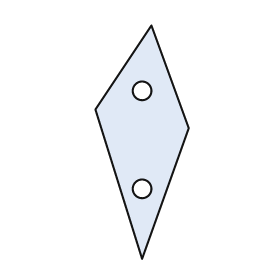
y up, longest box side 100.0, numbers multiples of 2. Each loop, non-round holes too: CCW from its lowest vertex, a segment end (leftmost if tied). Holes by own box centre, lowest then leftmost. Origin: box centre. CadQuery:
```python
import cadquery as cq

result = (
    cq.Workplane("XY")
    .moveTo(0.0, -50.0)
    .lineTo(20.0, 6.0)
    .lineTo(4.0, 50.0)
    .lineTo(-20.0, 14.0)
    .close()
    .moveTo(0.0, -20.0)
    .circle(4.0)
    .moveTo(0.0, 22.0)
    .circle(4.0)
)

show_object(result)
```